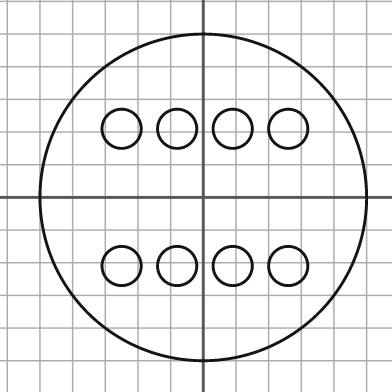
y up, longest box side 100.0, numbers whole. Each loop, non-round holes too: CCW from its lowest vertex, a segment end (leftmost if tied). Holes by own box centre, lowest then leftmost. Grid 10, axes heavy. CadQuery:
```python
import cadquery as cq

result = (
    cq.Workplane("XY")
    .moveTo(0.0, 0.0)
    .circle(50.0)
    .moveTo(-25.0, -21.0)
    .circle(6.0)
    .moveTo(-8.0, -21.0)
    .circle(6.0)
    .moveTo(9.0, -21.0)
    .circle(6.0)
    .moveTo(26.0, -21.0)
    .circle(6.0)
    .moveTo(-25.0, 21.0)
    .circle(6.0)
    .moveTo(-8.0, 21.0)
    .circle(6.0)
    .moveTo(9.0, 21.0)
    .circle(6.0)
    .moveTo(26.0, 21.0)
    .circle(6.0)
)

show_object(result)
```